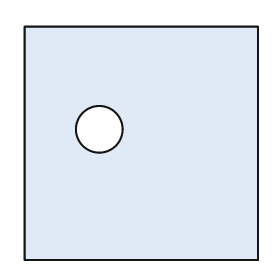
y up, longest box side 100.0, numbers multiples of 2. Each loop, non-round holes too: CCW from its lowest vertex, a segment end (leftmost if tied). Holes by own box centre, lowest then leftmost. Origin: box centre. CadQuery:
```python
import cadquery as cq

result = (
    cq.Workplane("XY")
    .moveTo(-50.0, -50.0)
    .lineTo(50.0, -50.0)
    .lineTo(50.0, 50.0)
    .lineTo(-50.0, 50.0)
    .close()
    .moveTo(-18.0, 6.0)
    .circle(10.0)
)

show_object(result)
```